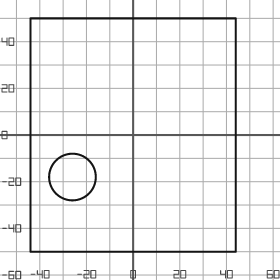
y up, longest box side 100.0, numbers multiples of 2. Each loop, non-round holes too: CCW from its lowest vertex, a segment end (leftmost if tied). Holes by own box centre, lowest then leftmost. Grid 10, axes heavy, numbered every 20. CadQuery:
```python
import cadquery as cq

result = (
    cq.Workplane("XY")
    .moveTo(-44.0, -50.0)
    .lineTo(44.0, -50.0)
    .lineTo(44.0, 50.0)
    .lineTo(-44.0, 50.0)
    .close()
    .moveTo(-26.0, -18.0)
    .circle(10.0)
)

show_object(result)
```